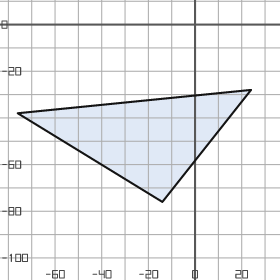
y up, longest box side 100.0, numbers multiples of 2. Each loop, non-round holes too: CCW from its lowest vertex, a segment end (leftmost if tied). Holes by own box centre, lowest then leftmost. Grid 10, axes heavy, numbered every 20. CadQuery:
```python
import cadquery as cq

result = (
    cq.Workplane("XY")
    .moveTo(-14.0, -76.0)
    .lineTo(24.0, -28.0)
    .lineTo(-76.0, -38.0)
    .close()
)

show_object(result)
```